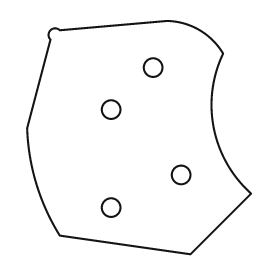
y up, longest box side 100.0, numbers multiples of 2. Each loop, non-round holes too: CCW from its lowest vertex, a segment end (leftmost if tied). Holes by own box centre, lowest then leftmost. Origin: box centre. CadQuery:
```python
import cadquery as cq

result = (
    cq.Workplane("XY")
    .moveTo(22.0, -50.0)
    .lineTo(48.0, -24.0)
    .threePointArc((32.0, 4.0), (36.0, 36.0))
    .threePointArc((26.0, 46.0), (12.0, 50.0))
    .lineTo(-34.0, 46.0)
    .threePointArc((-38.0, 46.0), (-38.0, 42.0))
    .lineTo(-48.0, 4.0)
    .threePointArc((-44.0, -20.0), (-34.0, -42.0))
    .close()
    .moveTo(-12.0, -30.0)
    .circle(4.0)
    .moveTo(18.0, -16.0)
    .circle(4.0)
    .moveTo(-12.0, 12.0)
    .circle(4.0)
    .moveTo(6.0, 30.0)
    .circle(4.0)
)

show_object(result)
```